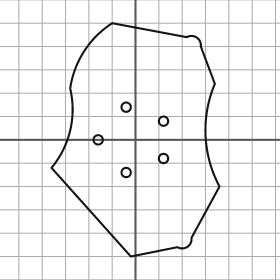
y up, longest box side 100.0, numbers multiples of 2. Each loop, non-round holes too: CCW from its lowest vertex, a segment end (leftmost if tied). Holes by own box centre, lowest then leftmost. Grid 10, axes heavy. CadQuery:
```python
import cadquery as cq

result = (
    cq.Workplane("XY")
    .moveTo(-2.0, -50.0)
    .lineTo(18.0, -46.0)
    .threePointArc((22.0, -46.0), (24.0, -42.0))
    .lineTo(36.0, -20.0)
    .threePointArc((30.0, 2.0), (34.0, 24.0))
    .lineTo(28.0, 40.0)
    .threePointArc((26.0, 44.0), (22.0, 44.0))
    .lineTo(-10.0, 50.0)
    .threePointArc((-22.0, 38.0), (-28.0, 22.0))
    .threePointArc((-28.0, 4.0), (-36.0, -12.0))
    .close()
    .moveTo(-4.0, -14.0)
    .circle(2.0)
    .moveTo(12.0, -8.0)
    .circle(2.0)
    .moveTo(-16.0, 0.0)
    .circle(2.0)
    .moveTo(12.0, 8.0)
    .circle(2.0)
    .moveTo(-4.0, 14.0)
    .circle(2.0)
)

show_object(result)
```